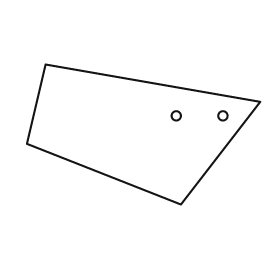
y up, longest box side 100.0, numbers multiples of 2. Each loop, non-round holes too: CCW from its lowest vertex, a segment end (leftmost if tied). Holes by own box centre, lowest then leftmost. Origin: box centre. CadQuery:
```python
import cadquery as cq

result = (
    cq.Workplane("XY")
    .moveTo(16.0, -30.0)
    .lineTo(50.0, 14.0)
    .lineTo(-42.0, 30.0)
    .lineTo(-50.0, -4.0)
    .close()
    .moveTo(14.0, 8.0)
    .circle(2.0)
    .moveTo(34.0, 8.0)
    .circle(2.0)
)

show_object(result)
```